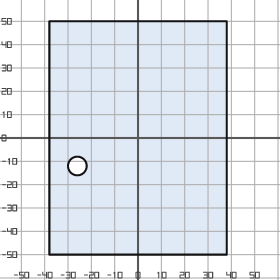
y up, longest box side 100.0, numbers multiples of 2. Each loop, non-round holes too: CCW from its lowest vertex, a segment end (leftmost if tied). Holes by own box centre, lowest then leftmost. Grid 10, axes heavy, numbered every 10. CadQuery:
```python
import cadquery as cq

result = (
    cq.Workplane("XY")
    .moveTo(-38.0, -50.0)
    .lineTo(38.0, -50.0)
    .lineTo(38.0, 50.0)
    .lineTo(-38.0, 50.0)
    .close()
    .moveTo(-26.0, -12.0)
    .circle(4.0)
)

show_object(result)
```